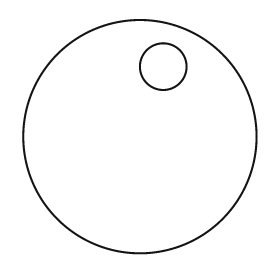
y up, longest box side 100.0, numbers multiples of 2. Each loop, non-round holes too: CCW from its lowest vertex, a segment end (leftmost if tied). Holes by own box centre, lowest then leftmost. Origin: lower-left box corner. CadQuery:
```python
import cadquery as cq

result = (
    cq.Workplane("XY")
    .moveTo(50.0, 50.0)
    .circle(50.0)
    .moveTo(60.0, 80.0)
    .circle(10.0)
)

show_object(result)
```